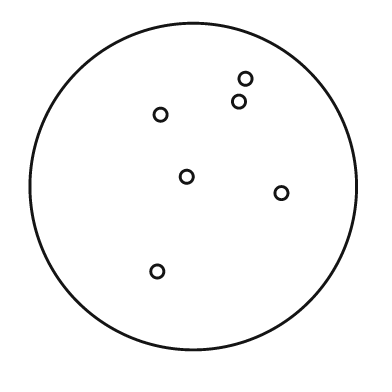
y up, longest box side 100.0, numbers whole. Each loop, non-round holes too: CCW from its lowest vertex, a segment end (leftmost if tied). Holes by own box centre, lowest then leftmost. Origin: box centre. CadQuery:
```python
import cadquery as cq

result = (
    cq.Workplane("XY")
    .moveTo(0.0, 0.0)
    .circle(50.0)
    .moveTo(-11.0, -26.0)
    .circle(2.0)
    .moveTo(27.0, -2.0)
    .circle(2.0)
    .moveTo(-2.0, 3.0)
    .circle(2.0)
    .moveTo(-10.0, 22.0)
    .circle(2.0)
    .moveTo(14.0, 26.0)
    .circle(2.0)
    .moveTo(16.0, 33.0)
    .circle(2.0)
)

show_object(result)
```